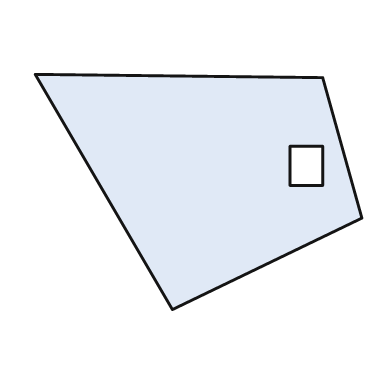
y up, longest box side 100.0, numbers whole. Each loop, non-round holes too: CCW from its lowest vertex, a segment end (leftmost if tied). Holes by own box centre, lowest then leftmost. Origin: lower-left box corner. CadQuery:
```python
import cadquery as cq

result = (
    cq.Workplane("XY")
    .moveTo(42.0, 0.0)
    .lineTo(100.0, 28.0)
    .lineTo(88.0, 71.0)
    .lineTo(0.0, 72.0)
    .close()
    .moveTo(78.0, 38.0)
    .lineTo(88.0, 38.0)
    .lineTo(88.0, 50.0)
    .lineTo(78.0, 50.0)
    .close()
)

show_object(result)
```